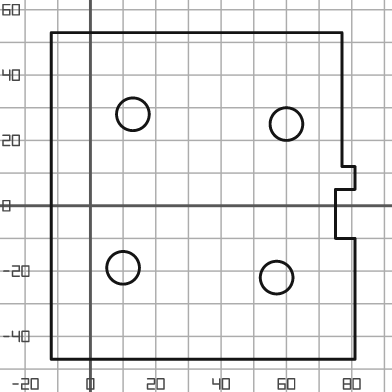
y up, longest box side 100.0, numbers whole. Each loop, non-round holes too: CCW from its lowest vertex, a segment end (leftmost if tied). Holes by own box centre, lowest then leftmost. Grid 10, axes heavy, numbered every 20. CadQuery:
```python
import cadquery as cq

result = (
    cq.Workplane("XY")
    .moveTo(-12.0, -47.0)
    .lineTo(81.0, -47.0)
    .lineTo(81.0, -10.0)
    .lineTo(75.0, -10.0)
    .lineTo(75.0, 5.0)
    .lineTo(81.0, 5.0)
    .lineTo(81.0, 12.0)
    .lineTo(77.0, 12.0)
    .lineTo(77.0, 53.0)
    .lineTo(-12.0, 53.0)
    .close()
    .moveTo(57.0, -22.0)
    .circle(5.0)
    .moveTo(10.0, -19.0)
    .circle(5.0)
    .moveTo(60.0, 25.0)
    .circle(5.0)
    .moveTo(13.0, 28.0)
    .circle(5.0)
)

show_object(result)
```